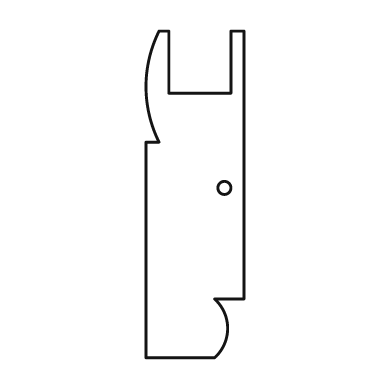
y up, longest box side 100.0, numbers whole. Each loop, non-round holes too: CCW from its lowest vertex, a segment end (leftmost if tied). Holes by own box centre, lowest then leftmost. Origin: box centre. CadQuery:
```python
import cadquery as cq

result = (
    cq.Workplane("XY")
    .moveTo(-15.0, -50.0)
    .lineTo(6.0, -50.0)
    .threePointArc((10.0, -41.0), (6.0, -32.0))
    .lineTo(15.0, -32.0)
    .lineTo(15.0, 50.0)
    .lineTo(11.0, 50.0)
    .lineTo(11.0, 31.0)
    .lineTo(-8.0, 31.0)
    .lineTo(-8.0, 50.0)
    .lineTo(-11.0, 50.0)
    .threePointArc((-15.0, 33.0), (-11.0, 16.0))
    .lineTo(-15.0, 16.0)
    .close()
    .moveTo(9.0, 2.0)
    .circle(2.0)
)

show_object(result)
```